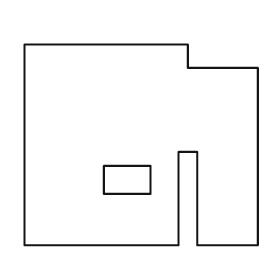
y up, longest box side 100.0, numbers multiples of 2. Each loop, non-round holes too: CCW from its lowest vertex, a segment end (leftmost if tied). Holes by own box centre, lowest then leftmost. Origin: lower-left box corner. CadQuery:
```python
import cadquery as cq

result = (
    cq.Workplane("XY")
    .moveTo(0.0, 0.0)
    .lineTo(66.0, 0.0)
    .lineTo(66.0, 40.0)
    .lineTo(74.0, 40.0)
    .lineTo(74.0, 0.0)
    .lineTo(100.0, 0.0)
    .lineTo(100.0, 76.0)
    .lineTo(70.0, 76.0)
    .lineTo(70.0, 86.0)
    .lineTo(0.0, 86.0)
    .close()
    .moveTo(34.0, 22.0)
    .lineTo(54.0, 22.0)
    .lineTo(54.0, 34.0)
    .lineTo(34.0, 34.0)
    .close()
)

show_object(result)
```